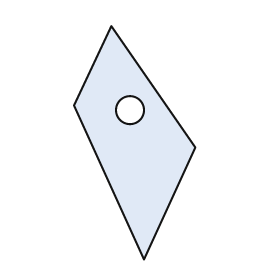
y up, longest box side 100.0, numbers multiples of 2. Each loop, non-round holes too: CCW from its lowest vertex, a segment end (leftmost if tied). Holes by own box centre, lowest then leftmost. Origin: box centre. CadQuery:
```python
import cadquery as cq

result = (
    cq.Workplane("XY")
    .moveTo(4.0, -50.0)
    .lineTo(26.0, -2.0)
    .lineTo(-10.0, 50.0)
    .lineTo(-26.0, 16.0)
    .close()
    .moveTo(-2.0, 14.0)
    .circle(6.0)
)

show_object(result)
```